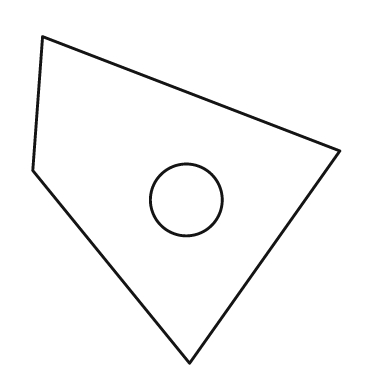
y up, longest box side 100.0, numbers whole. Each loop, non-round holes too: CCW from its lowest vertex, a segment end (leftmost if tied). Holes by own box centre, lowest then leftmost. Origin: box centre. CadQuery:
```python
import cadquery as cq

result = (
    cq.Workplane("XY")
    .moveTo(1.0, -50.0)
    .lineTo(47.0, 15.0)
    .lineTo(-44.0, 50.0)
    .lineTo(-47.0, 9.0)
    .close()
    .moveTo(0.0, 0.0)
    .circle(11.0)
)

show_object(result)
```